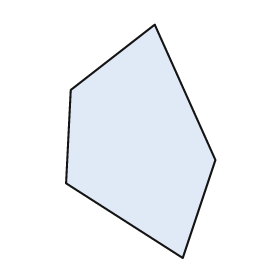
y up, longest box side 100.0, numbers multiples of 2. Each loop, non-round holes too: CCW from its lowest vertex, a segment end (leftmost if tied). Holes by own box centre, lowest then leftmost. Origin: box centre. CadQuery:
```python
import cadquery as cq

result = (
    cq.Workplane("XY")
    .moveTo(18.0, -50.0)
    .lineTo(32.0, -8.0)
    .lineTo(6.0, 50.0)
    .lineTo(-30.0, 22.0)
    .lineTo(-32.0, -18.0)
    .close()
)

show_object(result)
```